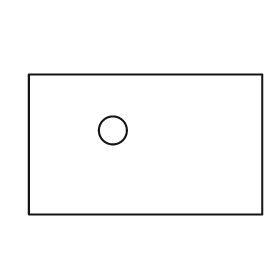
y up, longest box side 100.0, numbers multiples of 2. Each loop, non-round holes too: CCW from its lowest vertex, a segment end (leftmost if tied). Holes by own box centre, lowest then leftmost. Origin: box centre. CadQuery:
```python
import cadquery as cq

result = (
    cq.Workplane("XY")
    .moveTo(-50.0, -30.0)
    .lineTo(50.0, -30.0)
    .lineTo(50.0, 30.0)
    .lineTo(-50.0, 30.0)
    .close()
    .moveTo(-14.0, 6.0)
    .circle(6.0)
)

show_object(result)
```